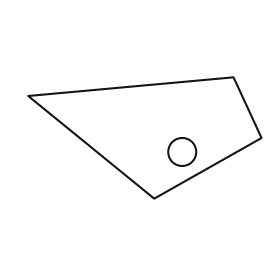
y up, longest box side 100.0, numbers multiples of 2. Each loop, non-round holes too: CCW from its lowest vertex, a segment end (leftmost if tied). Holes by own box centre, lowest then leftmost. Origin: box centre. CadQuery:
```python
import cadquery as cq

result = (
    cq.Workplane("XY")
    .moveTo(4.0, -26.0)
    .lineTo(50.0, 0.0)
    .lineTo(38.0, 26.0)
    .lineTo(-50.0, 18.0)
    .close()
    .moveTo(16.0, -6.0)
    .circle(6.0)
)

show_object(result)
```